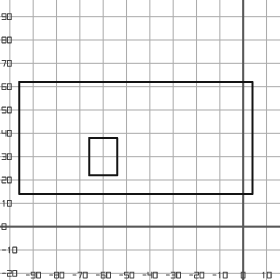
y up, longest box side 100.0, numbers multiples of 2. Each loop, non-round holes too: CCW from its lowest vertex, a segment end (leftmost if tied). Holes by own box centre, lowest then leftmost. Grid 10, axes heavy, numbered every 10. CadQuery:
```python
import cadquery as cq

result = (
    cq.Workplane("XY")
    .moveTo(-96.0, 14.0)
    .lineTo(4.0, 14.0)
    .lineTo(4.0, 62.0)
    .lineTo(-96.0, 62.0)
    .close()
    .moveTo(-66.0, 22.0)
    .lineTo(-54.0, 22.0)
    .lineTo(-54.0, 38.0)
    .lineTo(-66.0, 38.0)
    .close()
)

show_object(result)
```